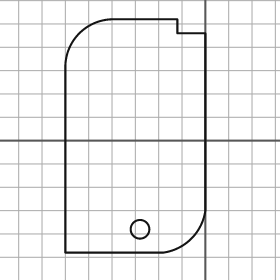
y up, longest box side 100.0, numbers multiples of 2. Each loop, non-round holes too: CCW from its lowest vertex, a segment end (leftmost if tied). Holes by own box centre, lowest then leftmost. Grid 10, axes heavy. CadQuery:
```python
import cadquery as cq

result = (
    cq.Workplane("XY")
    .moveTo(-60.0, -48.0)
    .lineTo(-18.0, -48.0)
    .threePointArc((-6.0, -42.0), (0.0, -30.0))
    .lineTo(0.0, 46.0)
    .lineTo(-12.0, 46.0)
    .lineTo(-12.0, 52.0)
    .lineTo(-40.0, 52.0)
    .threePointArc((-54.0, 46.0), (-60.0, 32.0))
    .close()
    .moveTo(-28.0, -38.0)
    .circle(4.0)
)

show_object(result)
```